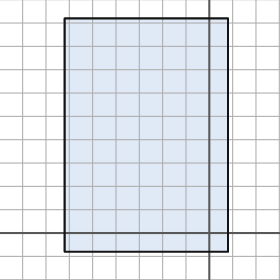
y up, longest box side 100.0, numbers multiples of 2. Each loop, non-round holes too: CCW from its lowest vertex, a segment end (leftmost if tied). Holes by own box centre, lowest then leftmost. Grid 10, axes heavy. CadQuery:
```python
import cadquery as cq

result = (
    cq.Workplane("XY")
    .moveTo(-62.0, -8.0)
    .lineTo(8.0, -8.0)
    .lineTo(8.0, 92.0)
    .lineTo(-62.0, 92.0)
    .close()
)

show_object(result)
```